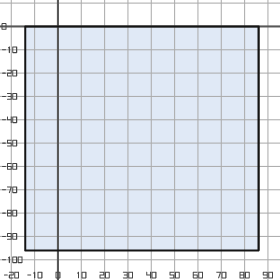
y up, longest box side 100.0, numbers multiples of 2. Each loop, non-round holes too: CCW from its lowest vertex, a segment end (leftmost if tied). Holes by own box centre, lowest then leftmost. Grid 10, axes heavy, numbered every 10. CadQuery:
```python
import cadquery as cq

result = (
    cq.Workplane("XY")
    .moveTo(-14.0, -96.0)
    .lineTo(86.0, -96.0)
    .lineTo(86.0, 0.0)
    .lineTo(-14.0, 0.0)
    .close()
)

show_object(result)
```